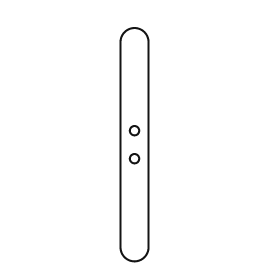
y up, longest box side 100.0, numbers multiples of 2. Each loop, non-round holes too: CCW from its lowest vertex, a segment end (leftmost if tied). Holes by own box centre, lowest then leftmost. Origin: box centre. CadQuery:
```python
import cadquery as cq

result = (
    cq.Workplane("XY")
    .moveTo(-6.0, -44.0)
    .threePointArc((0.0, -50.0), (6.0, -44.0))
    .lineTo(6.0, 44.0)
    .threePointArc((0.0, 50.0), (-6.0, 44.0))
    .close()
    .moveTo(0.0, -6.0)
    .circle(2.0)
    .moveTo(0.0, 6.0)
    .circle(2.0)
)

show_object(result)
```